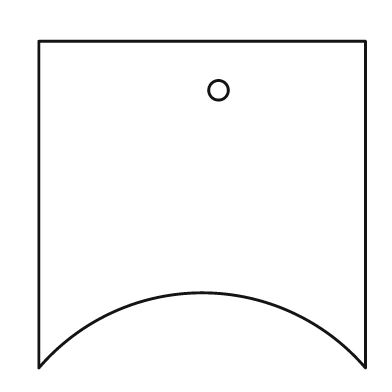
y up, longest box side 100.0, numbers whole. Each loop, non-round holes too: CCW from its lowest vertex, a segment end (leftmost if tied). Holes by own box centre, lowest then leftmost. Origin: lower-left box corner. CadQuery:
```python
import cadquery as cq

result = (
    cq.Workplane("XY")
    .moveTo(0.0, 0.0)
    .threePointArc((50.0, 23.0), (100.0, 0.0))
    .lineTo(100.0, 100.0)
    .lineTo(0.0, 100.0)
    .close()
    .moveTo(55.0, 85.0)
    .circle(3.0)
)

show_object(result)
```